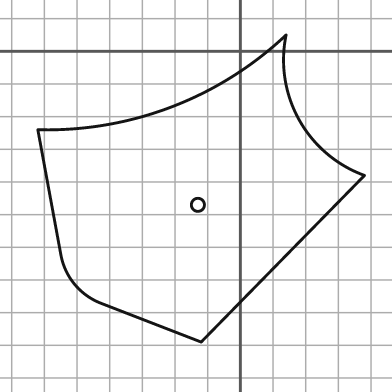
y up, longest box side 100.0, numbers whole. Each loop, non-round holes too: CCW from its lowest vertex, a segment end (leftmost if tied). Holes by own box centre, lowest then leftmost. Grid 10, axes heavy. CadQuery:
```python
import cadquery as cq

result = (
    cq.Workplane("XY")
    .moveTo(-12.0, -89.0)
    .lineTo(38.0, -38.0)
    .threePointArc((18.0, -21.0), (14.0, 5.0))
    .threePointArc((-21.0, -17.0), (-62.0, -24.0))
    .lineTo(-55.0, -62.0)
    .threePointArc((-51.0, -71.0), (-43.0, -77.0))
    .close()
    .moveTo(-13.0, -47.0)
    .circle(2.0)
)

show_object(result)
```